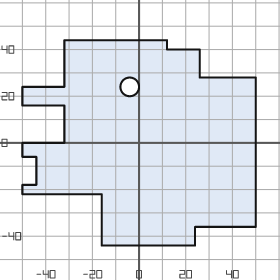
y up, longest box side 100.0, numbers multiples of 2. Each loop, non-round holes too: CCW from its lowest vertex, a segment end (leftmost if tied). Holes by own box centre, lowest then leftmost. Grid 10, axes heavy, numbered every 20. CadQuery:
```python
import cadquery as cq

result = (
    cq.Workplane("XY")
    .moveTo(-16.0, -44.0)
    .lineTo(24.0, -44.0)
    .lineTo(24.0, -36.0)
    .lineTo(50.0, -36.0)
    .lineTo(50.0, 28.0)
    .lineTo(26.0, 28.0)
    .lineTo(26.0, 40.0)
    .lineTo(12.0, 40.0)
    .lineTo(12.0, 44.0)
    .lineTo(-32.0, 44.0)
    .lineTo(-32.0, 24.0)
    .lineTo(-50.0, 24.0)
    .lineTo(-50.0, 16.0)
    .lineTo(-32.0, 16.0)
    .lineTo(-32.0, 0.0)
    .lineTo(-50.0, 0.0)
    .lineTo(-50.0, -6.0)
    .lineTo(-44.0, -6.0)
    .lineTo(-44.0, -18.0)
    .lineTo(-50.0, -18.0)
    .lineTo(-50.0, -22.0)
    .lineTo(-16.0, -22.0)
    .close()
    .moveTo(-4.0, 24.0)
    .circle(4.0)
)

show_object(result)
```